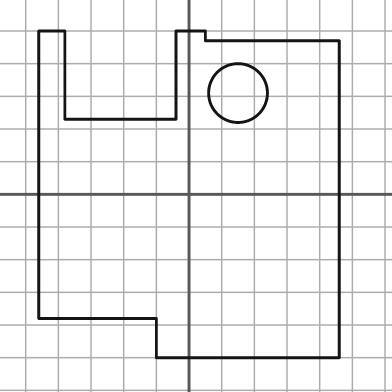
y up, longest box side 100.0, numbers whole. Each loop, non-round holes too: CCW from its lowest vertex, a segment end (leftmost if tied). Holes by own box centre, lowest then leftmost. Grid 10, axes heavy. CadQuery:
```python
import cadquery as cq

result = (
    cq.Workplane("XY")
    .moveTo(-10.0, -50.0)
    .lineTo(46.0, -50.0)
    .lineTo(46.0, 47.0)
    .lineTo(5.0, 47.0)
    .lineTo(5.0, 50.0)
    .lineTo(-4.0, 50.0)
    .lineTo(-4.0, 23.0)
    .lineTo(-38.0, 23.0)
    .lineTo(-38.0, 50.0)
    .lineTo(-46.0, 50.0)
    .lineTo(-46.0, -38.0)
    .lineTo(-10.0, -38.0)
    .close()
    .moveTo(15.0, 31.0)
    .circle(9.0)
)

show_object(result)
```